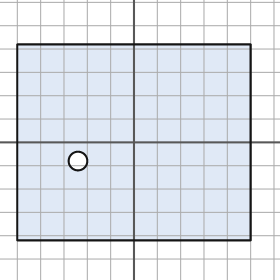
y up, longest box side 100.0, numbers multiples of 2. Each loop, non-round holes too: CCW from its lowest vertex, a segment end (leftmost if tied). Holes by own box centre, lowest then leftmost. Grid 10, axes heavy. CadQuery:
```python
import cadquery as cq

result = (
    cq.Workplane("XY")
    .moveTo(-50.0, -42.0)
    .lineTo(50.0, -42.0)
    .lineTo(50.0, 42.0)
    .lineTo(-50.0, 42.0)
    .close()
    .moveTo(-24.0, -8.0)
    .circle(4.0)
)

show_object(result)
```